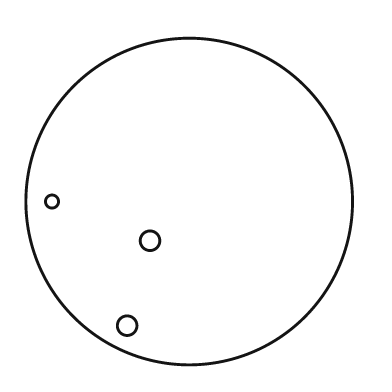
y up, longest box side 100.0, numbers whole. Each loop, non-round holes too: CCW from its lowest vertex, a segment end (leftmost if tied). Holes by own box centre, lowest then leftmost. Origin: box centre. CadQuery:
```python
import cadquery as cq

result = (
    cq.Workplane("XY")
    .moveTo(0.0, 0.0)
    .circle(50.0)
    .moveTo(-19.0, -38.0)
    .circle(3.0)
    .moveTo(-12.0, -12.0)
    .circle(3.0)
    .moveTo(-42.0, 0.0)
    .circle(2.0)
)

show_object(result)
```